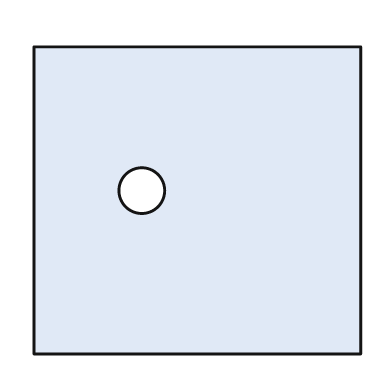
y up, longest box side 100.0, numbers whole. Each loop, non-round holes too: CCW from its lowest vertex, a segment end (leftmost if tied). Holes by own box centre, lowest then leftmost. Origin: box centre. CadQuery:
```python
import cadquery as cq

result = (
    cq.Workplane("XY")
    .moveTo(-50.0, -47.0)
    .lineTo(50.0, -47.0)
    .lineTo(50.0, 47.0)
    .lineTo(-50.0, 47.0)
    .close()
    .moveTo(-17.0, 3.0)
    .circle(7.0)
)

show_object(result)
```